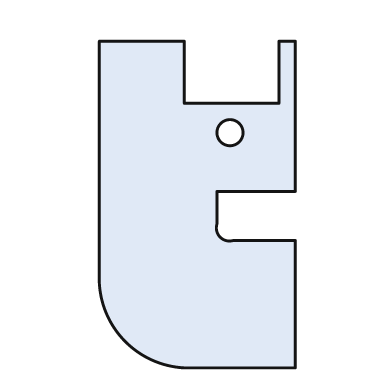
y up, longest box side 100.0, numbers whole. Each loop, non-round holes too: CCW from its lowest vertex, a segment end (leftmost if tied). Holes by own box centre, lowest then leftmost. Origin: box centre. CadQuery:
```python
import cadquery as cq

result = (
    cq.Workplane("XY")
    .moveTo(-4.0, -50.0)
    .lineTo(30.0, -50.0)
    .lineTo(30.0, -11.0)
    .lineTo(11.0, -11.0)
    .threePointArc((7.0, -10.0), (6.0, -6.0))
    .lineTo(6.0, 4.0)
    .lineTo(30.0, 4.0)
    .lineTo(30.0, 50.0)
    .lineTo(25.0, 50.0)
    .lineTo(25.0, 31.0)
    .lineTo(-4.0, 31.0)
    .lineTo(-4.0, 50.0)
    .lineTo(-30.0, 50.0)
    .lineTo(-30.0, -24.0)
    .threePointArc((-22.0, -42.0), (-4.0, -50.0))
    .close()
    .moveTo(10.0, 22.0)
    .circle(4.0)
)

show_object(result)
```